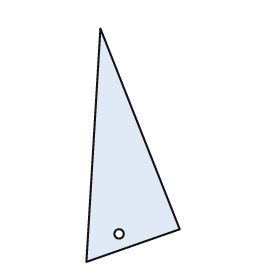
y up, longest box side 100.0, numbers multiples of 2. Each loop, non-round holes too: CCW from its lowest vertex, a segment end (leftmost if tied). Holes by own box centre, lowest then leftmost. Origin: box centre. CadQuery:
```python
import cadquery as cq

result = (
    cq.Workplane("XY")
    .moveTo(-20.0, -50.0)
    .lineTo(20.0, -36.0)
    .lineTo(-14.0, 50.0)
    .close()
    .moveTo(-6.0, -38.0)
    .circle(2.0)
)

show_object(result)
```